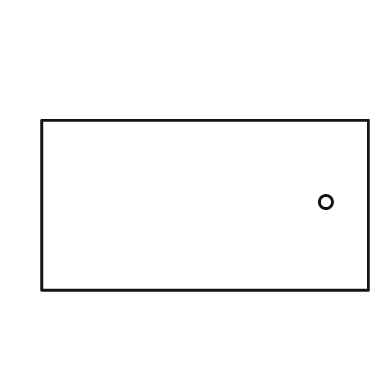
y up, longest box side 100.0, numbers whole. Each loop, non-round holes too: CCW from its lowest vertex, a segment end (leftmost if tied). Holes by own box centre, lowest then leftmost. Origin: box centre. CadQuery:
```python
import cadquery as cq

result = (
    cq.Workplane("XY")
    .moveTo(-50.0, -26.0)
    .lineTo(50.0, -26.0)
    .lineTo(50.0, 26.0)
    .lineTo(-50.0, 26.0)
    .close()
    .moveTo(37.0, 1.0)
    .circle(2.0)
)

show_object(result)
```